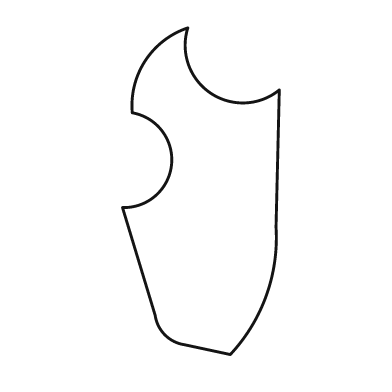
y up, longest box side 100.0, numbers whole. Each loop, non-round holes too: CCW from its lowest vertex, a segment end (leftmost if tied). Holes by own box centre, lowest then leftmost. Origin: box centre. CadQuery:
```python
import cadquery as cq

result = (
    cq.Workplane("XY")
    .moveTo(9.0, -50.0)
    .threePointArc((20.0, -32.0), (23.0, -11.0))
    .lineTo(24.0, 31.0)
    .threePointArc((3.0, 30.0), (-4.0, 50.0))
    .threePointArc((-17.0, 40.0), (-21.0, 24.0))
    .threePointArc((-9.0, 8.0), (-24.0, -5.0))
    .lineTo(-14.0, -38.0)
    .threePointArc((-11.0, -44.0), (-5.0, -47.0))
    .close()
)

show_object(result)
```